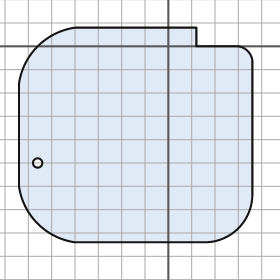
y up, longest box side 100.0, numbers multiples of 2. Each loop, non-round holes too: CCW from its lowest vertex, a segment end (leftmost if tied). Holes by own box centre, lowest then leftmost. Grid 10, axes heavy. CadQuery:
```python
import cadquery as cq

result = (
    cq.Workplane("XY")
    .moveTo(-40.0, -84.0)
    .lineTo(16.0, -84.0)
    .threePointArc((30.0, -78.0), (36.0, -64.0))
    .lineTo(36.0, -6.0)
    .threePointArc((34.0, -2.0), (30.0, 0.0))
    .lineTo(12.0, 0.0)
    .lineTo(12.0, 8.0)
    .lineTo(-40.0, 8.0)
    .threePointArc((-56.0, 0.0), (-64.0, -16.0))
    .lineTo(-64.0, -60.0)
    .threePointArc((-56.0, -76.0), (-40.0, -84.0))
    .close()
    .moveTo(-56.0, -50.0)
    .circle(2.0)
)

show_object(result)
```